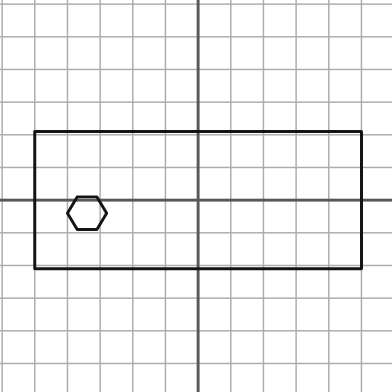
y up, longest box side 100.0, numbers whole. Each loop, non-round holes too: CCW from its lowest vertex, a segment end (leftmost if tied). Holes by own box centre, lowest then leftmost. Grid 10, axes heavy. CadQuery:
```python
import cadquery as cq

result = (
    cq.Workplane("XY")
    .moveTo(-50.0, -21.0)
    .lineTo(50.0, -21.0)
    .lineTo(50.0, 21.0)
    .lineTo(-50.0, 21.0)
    .close()
    .moveTo(-37.0, -9.0)
    .lineTo(-31.0, -9.0)
    .lineTo(-28.0, -4.0)
    .lineTo(-31.0, 1.0)
    .lineTo(-37.0, 1.0)
    .lineTo(-40.0, -4.0)
    .close()
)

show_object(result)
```